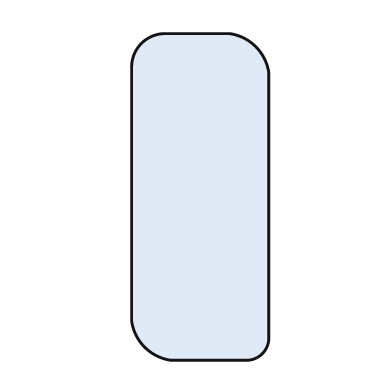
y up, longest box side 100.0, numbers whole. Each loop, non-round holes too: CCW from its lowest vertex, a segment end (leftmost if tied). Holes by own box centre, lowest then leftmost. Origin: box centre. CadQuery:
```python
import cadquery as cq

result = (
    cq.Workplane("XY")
    .moveTo(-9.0, -50.0)
    .lineTo(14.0, -50.0)
    .threePointArc((19.0, -48.0), (21.0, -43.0))
    .lineTo(21.0, 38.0)
    .threePointArc((17.0, 46.0), (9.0, 50.0))
    .lineTo(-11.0, 50.0)
    .threePointArc((-18.0, 47.0), (-21.0, 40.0))
    .lineTo(-21.0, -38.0)
    .threePointArc((-17.0, -46.0), (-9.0, -50.0))
    .close()
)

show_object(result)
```